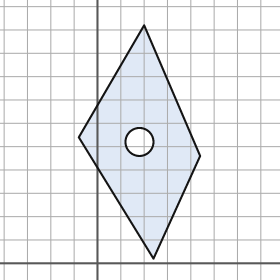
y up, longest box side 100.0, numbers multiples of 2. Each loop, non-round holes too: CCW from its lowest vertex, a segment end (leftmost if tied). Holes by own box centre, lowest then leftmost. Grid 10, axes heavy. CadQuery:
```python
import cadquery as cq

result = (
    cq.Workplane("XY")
    .moveTo(24.0, 2.0)
    .lineTo(44.0, 46.0)
    .lineTo(20.0, 102.0)
    .lineTo(-8.0, 54.0)
    .close()
    .moveTo(18.0, 52.0)
    .circle(6.0)
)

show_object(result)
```